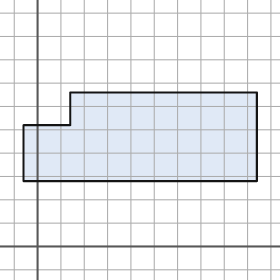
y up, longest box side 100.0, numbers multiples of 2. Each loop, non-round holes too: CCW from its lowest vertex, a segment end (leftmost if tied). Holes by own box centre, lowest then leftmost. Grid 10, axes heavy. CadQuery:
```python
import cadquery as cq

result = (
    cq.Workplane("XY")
    .moveTo(-6.0, 28.0)
    .lineTo(94.0, 28.0)
    .lineTo(94.0, 66.0)
    .lineTo(14.0, 66.0)
    .lineTo(14.0, 52.0)
    .lineTo(-6.0, 52.0)
    .close()
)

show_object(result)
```